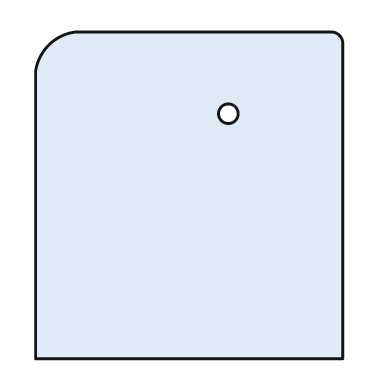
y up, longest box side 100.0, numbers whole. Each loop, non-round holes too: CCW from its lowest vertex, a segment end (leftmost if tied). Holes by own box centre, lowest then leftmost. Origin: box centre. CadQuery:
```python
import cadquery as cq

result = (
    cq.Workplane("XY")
    .moveTo(-47.0, -50.0)
    .lineTo(47.0, -50.0)
    .lineTo(47.0, 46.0)
    .threePointArc((46.0, 49.0), (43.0, 50.0))
    .lineTo(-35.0, 50.0)
    .threePointArc((-43.0, 46.0), (-47.0, 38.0))
    .close()
    .moveTo(12.0, 25.0)
    .circle(3.0)
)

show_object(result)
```